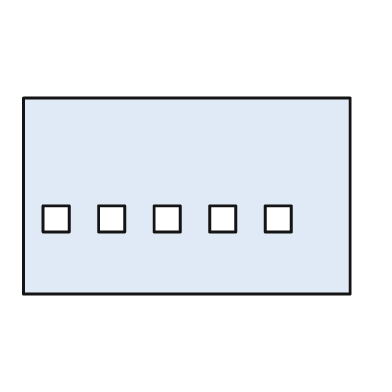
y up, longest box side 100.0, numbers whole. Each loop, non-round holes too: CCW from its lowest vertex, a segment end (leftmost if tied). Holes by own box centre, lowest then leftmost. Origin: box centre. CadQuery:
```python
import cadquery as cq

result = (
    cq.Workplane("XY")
    .moveTo(-50.0, -30.0)
    .lineTo(50.0, -30.0)
    .lineTo(50.0, 30.0)
    .lineTo(-50.0, 30.0)
    .close()
    .moveTo(-44.0, -11.0)
    .lineTo(-36.0, -11.0)
    .lineTo(-36.0, -3.0)
    .lineTo(-44.0, -3.0)
    .close()
    .moveTo(-27.0, -11.0)
    .lineTo(-19.0, -11.0)
    .lineTo(-19.0, -3.0)
    .lineTo(-27.0, -3.0)
    .close()
    .moveTo(-10.0, -11.0)
    .lineTo(-2.0, -11.0)
    .lineTo(-2.0, -3.0)
    .lineTo(-10.0, -3.0)
    .close()
    .moveTo(7.0, -11.0)
    .lineTo(15.0, -11.0)
    .lineTo(15.0, -3.0)
    .lineTo(7.0, -3.0)
    .close()
    .moveTo(24.0, -11.0)
    .lineTo(32.0, -11.0)
    .lineTo(32.0, -3.0)
    .lineTo(24.0, -3.0)
    .close()
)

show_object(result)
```